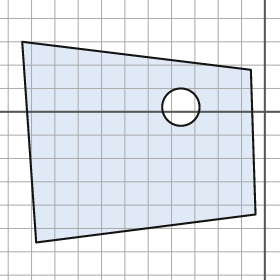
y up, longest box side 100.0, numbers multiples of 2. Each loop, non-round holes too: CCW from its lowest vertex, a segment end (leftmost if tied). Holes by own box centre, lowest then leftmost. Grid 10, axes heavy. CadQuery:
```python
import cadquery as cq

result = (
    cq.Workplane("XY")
    .moveTo(-98.0, -56.0)
    .lineTo(-4.0, -44.0)
    .lineTo(-6.0, 18.0)
    .lineTo(-104.0, 30.0)
    .close()
    .moveTo(-36.0, 2.0)
    .circle(8.0)
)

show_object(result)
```